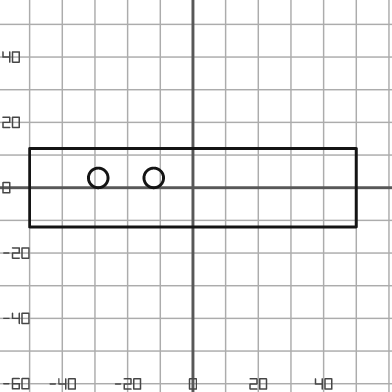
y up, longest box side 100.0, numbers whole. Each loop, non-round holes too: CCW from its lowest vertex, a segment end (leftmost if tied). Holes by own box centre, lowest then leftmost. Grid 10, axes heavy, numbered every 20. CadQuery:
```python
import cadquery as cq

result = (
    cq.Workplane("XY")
    .moveTo(-50.0, -12.0)
    .lineTo(50.0, -12.0)
    .lineTo(50.0, 12.0)
    .lineTo(-50.0, 12.0)
    .close()
    .moveTo(-29.0, 3.0)
    .circle(3.0)
    .moveTo(-12.0, 3.0)
    .circle(3.0)
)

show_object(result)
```